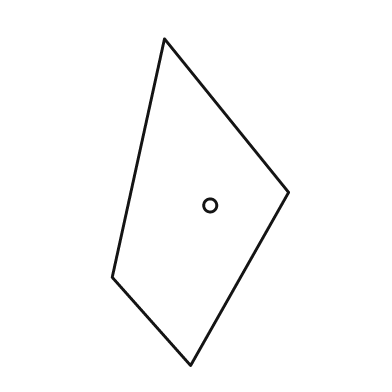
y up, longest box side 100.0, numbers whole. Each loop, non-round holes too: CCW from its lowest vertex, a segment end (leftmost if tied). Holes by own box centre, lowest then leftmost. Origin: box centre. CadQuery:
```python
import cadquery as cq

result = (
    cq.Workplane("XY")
    .moveTo(-3.0, -50.0)
    .lineTo(27.0, 3.0)
    .lineTo(-11.0, 50.0)
    .lineTo(-27.0, -23.0)
    .close()
    .moveTo(3.0, -1.0)
    .circle(2.0)
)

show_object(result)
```